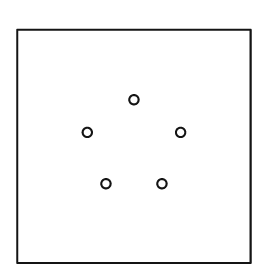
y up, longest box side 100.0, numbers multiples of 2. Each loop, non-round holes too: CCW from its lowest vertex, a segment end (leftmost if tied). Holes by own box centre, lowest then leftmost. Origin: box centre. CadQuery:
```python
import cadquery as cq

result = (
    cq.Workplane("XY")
    .moveTo(-50.0, -50.0)
    .lineTo(50.0, -50.0)
    .lineTo(50.0, 50.0)
    .lineTo(-50.0, 50.0)
    .close()
    .moveTo(-12.0, -16.0)
    .circle(2.0)
    .moveTo(12.0, -16.0)
    .circle(2.0)
    .moveTo(-20.0, 6.0)
    .circle(2.0)
    .moveTo(20.0, 6.0)
    .circle(2.0)
    .moveTo(0.0, 20.0)
    .circle(2.0)
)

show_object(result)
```